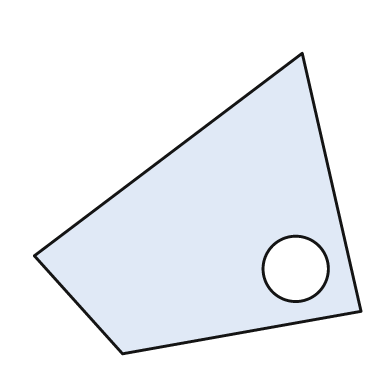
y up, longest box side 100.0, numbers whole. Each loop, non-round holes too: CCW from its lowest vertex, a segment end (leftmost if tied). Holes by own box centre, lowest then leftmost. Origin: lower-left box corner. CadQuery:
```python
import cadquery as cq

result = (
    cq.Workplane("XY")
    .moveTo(27.0, 0.0)
    .lineTo(100.0, 13.0)
    .lineTo(82.0, 92.0)
    .lineTo(0.0, 30.0)
    .close()
    .moveTo(80.0, 26.0)
    .circle(10.0)
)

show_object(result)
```